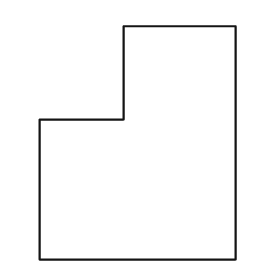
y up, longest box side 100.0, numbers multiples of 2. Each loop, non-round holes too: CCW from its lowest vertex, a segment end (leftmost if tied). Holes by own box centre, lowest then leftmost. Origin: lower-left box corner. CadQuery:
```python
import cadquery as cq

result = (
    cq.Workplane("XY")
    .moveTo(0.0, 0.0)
    .lineTo(84.0, 0.0)
    .lineTo(84.0, 100.0)
    .lineTo(36.0, 100.0)
    .lineTo(36.0, 60.0)
    .lineTo(0.0, 60.0)
    .close()
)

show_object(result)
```